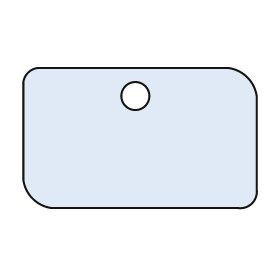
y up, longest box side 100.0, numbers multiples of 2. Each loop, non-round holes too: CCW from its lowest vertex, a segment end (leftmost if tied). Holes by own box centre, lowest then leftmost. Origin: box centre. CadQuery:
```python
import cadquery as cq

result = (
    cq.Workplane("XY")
    .moveTo(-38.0, -30.0)
    .lineTo(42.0, -30.0)
    .threePointArc((48.0, -28.0), (50.0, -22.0))
    .lineTo(50.0, 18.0)
    .threePointArc((46.0, 26.0), (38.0, 30.0))
    .lineTo(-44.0, 30.0)
    .threePointArc((-48.0, 28.0), (-50.0, 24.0))
    .lineTo(-50.0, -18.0)
    .threePointArc((-46.0, -26.0), (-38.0, -30.0))
    .close()
    .moveTo(-2.0, 18.0)
    .circle(6.0)
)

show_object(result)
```